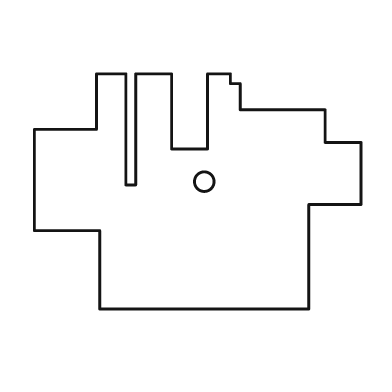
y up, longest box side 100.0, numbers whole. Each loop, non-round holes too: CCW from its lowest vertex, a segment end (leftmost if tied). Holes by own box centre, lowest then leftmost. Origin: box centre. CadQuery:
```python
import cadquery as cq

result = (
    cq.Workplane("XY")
    .moveTo(-30.0, -36.0)
    .lineTo(34.0, -36.0)
    .lineTo(34.0, -4.0)
    .lineTo(50.0, -4.0)
    .lineTo(50.0, 15.0)
    .lineTo(39.0, 15.0)
    .lineTo(39.0, 25.0)
    .lineTo(13.0, 25.0)
    .lineTo(13.0, 33.0)
    .lineTo(10.0, 33.0)
    .lineTo(10.0, 36.0)
    .lineTo(3.0, 36.0)
    .lineTo(3.0, 13.0)
    .lineTo(-8.0, 13.0)
    .lineTo(-8.0, 36.0)
    .lineTo(-19.0, 36.0)
    .lineTo(-19.0, 2.0)
    .lineTo(-22.0, 2.0)
    .lineTo(-22.0, 36.0)
    .lineTo(-31.0, 36.0)
    .lineTo(-31.0, 19.0)
    .lineTo(-50.0, 19.0)
    .lineTo(-50.0, -12.0)
    .lineTo(-30.0, -12.0)
    .close()
    .moveTo(2.0, 3.0)
    .circle(3.0)
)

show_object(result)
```